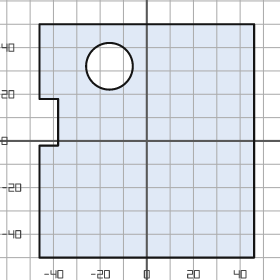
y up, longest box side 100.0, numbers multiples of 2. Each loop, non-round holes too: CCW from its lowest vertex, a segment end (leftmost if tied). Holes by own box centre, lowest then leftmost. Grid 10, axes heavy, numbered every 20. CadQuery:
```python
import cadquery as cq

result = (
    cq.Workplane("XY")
    .moveTo(-46.0, -50.0)
    .lineTo(46.0, -50.0)
    .lineTo(46.0, 50.0)
    .lineTo(-46.0, 50.0)
    .lineTo(-46.0, 18.0)
    .lineTo(-38.0, 18.0)
    .lineTo(-38.0, -2.0)
    .lineTo(-46.0, -2.0)
    .close()
    .moveTo(-16.0, 32.0)
    .circle(10.0)
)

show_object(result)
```